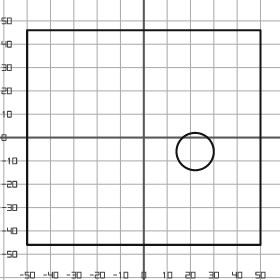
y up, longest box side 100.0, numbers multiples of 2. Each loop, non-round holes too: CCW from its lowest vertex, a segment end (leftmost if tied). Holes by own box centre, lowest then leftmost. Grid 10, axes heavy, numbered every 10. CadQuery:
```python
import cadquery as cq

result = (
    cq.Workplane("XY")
    .moveTo(-50.0, -46.0)
    .lineTo(50.0, -46.0)
    .lineTo(50.0, 46.0)
    .lineTo(-50.0, 46.0)
    .close()
    .moveTo(22.0, -6.0)
    .circle(8.0)
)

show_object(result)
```